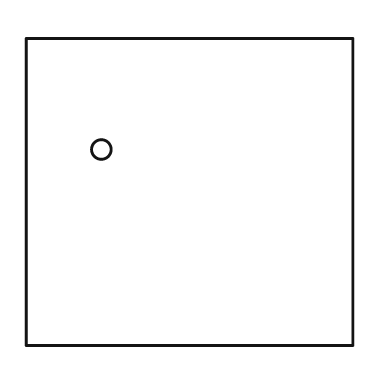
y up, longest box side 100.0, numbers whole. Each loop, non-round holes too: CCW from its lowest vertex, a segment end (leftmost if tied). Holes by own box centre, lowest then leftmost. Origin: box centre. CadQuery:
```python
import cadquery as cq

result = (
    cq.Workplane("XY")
    .moveTo(-50.0, -47.0)
    .lineTo(50.0, -47.0)
    .lineTo(50.0, 47.0)
    .lineTo(-50.0, 47.0)
    .close()
    .moveTo(-27.0, 13.0)
    .circle(3.0)
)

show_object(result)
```